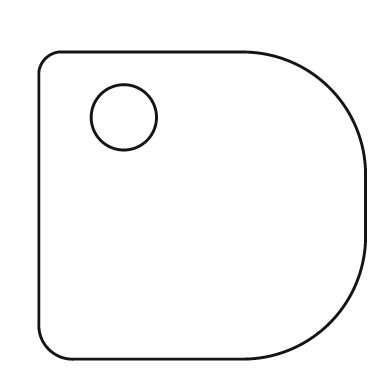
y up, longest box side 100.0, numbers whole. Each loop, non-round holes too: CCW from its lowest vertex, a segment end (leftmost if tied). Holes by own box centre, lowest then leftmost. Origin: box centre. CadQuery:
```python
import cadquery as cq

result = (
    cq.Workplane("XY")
    .moveTo(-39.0, -47.0)
    .lineTo(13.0, -47.0)
    .threePointArc((39.0, -36.0), (50.0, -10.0))
    .lineTo(50.0, 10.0)
    .threePointArc((39.0, 36.0), (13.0, 47.0))
    .lineTo(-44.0, 47.0)
    .threePointArc((-48.0, 45.0), (-50.0, 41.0))
    .lineTo(-50.0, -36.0)
    .threePointArc((-47.0, -44.0), (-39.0, -47.0))
    .close()
    .moveTo(-24.0, 27.0)
    .circle(10.0)
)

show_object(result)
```